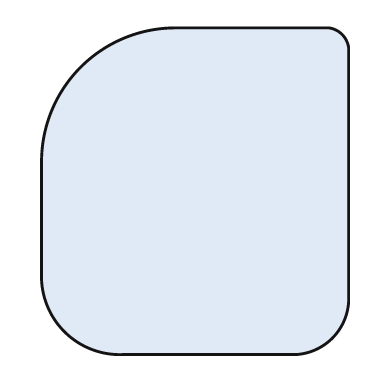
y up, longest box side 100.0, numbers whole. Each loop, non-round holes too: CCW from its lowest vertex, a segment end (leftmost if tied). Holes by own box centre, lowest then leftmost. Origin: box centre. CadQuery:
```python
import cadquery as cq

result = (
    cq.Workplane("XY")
    .moveTo(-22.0, -50.0)
    .lineTo(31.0, -50.0)
    .threePointArc((42.0, -45.0), (47.0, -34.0))
    .lineTo(47.0, 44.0)
    .threePointArc((45.0, 48.0), (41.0, 50.0))
    .lineTo(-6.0, 50.0)
    .threePointArc((-35.0, 38.0), (-47.0, 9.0))
    .lineTo(-47.0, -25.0)
    .threePointArc((-40.0, -43.0), (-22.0, -50.0))
    .close()
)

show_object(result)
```